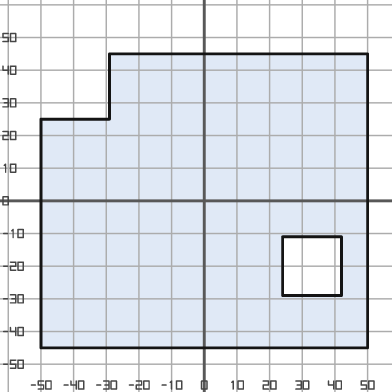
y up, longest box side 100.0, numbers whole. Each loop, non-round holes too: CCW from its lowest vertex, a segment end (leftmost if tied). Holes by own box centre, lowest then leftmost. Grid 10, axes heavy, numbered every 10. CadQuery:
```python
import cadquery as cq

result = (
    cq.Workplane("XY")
    .moveTo(-50.0, -45.0)
    .lineTo(50.0, -45.0)
    .lineTo(50.0, 45.0)
    .lineTo(-29.0, 45.0)
    .lineTo(-29.0, 25.0)
    .lineTo(-50.0, 25.0)
    .close()
    .moveTo(24.0, -29.0)
    .lineTo(42.0, -29.0)
    .lineTo(42.0, -11.0)
    .lineTo(24.0, -11.0)
    .close()
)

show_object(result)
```